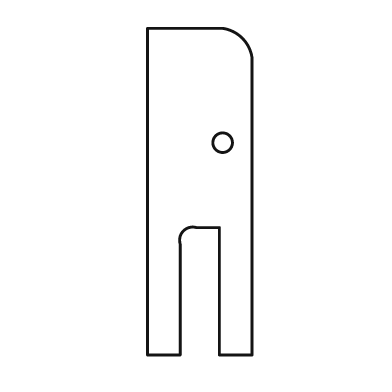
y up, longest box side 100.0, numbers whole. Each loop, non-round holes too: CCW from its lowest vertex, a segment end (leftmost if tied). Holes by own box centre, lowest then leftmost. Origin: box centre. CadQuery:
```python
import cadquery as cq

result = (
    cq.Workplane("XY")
    .moveTo(-16.0, -50.0)
    .lineTo(-6.0, -50.0)
    .lineTo(-6.0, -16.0)
    .threePointArc((-5.0, -12.0), (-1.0, -11.0))
    .lineTo(6.0, -11.0)
    .lineTo(6.0, -50.0)
    .lineTo(16.0, -50.0)
    .lineTo(16.0, 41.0)
    .threePointArc((13.0, 47.0), (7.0, 50.0))
    .lineTo(-16.0, 50.0)
    .close()
    .moveTo(7.0, 15.0)
    .circle(3.0)
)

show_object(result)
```